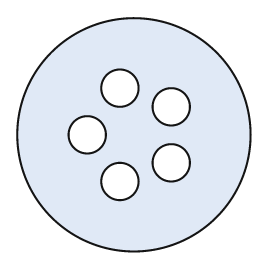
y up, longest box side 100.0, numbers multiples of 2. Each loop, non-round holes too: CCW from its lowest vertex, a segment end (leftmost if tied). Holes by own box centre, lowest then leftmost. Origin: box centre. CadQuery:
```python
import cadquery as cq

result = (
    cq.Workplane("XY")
    .moveTo(0.0, 0.0)
    .circle(50.0)
    .moveTo(-6.0, -20.0)
    .circle(8.0)
    .moveTo(16.0, -12.0)
    .circle(8.0)
    .moveTo(-20.0, 0.0)
    .circle(8.0)
    .moveTo(16.0, 12.0)
    .circle(8.0)
    .moveTo(-6.0, 20.0)
    .circle(8.0)
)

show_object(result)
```